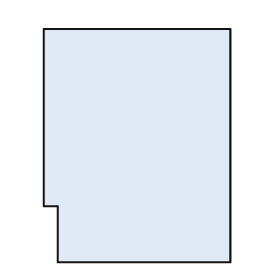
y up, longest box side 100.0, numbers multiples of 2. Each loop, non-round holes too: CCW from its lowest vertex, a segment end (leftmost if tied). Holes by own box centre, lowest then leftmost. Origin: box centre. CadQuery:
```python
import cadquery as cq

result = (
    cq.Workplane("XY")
    .moveTo(-34.0, -50.0)
    .lineTo(40.0, -50.0)
    .lineTo(40.0, 50.0)
    .lineTo(-40.0, 50.0)
    .lineTo(-40.0, -26.0)
    .lineTo(-34.0, -26.0)
    .close()
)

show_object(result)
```